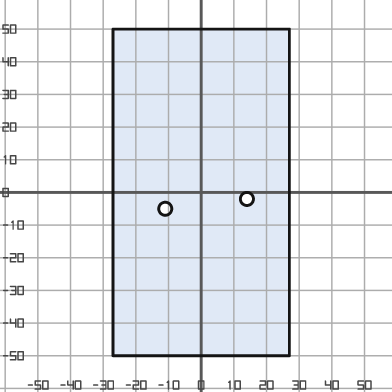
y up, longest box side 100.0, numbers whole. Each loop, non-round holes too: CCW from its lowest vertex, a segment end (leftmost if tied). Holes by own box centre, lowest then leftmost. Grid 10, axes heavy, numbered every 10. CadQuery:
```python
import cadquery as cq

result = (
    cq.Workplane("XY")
    .moveTo(-27.0, -50.0)
    .lineTo(27.0, -50.0)
    .lineTo(27.0, 50.0)
    .lineTo(-27.0, 50.0)
    .close()
    .moveTo(-11.0, -5.0)
    .circle(2.0)
    .moveTo(14.0, -2.0)
    .circle(2.0)
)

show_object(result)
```